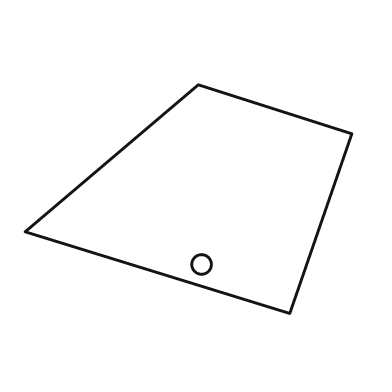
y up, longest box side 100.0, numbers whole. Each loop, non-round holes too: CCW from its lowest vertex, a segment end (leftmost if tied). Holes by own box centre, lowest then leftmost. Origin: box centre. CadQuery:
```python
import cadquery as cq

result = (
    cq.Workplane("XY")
    .moveTo(31.0, -35.0)
    .lineTo(50.0, 20.0)
    .lineTo(3.0, 35.0)
    .lineTo(-50.0, -10.0)
    .close()
    .moveTo(4.0, -20.0)
    .circle(3.0)
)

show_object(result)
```